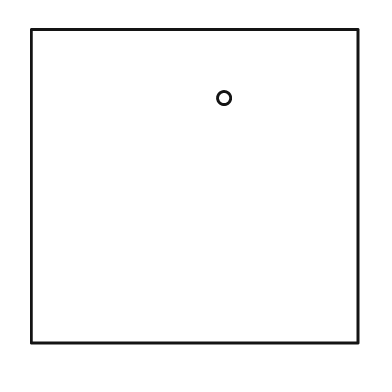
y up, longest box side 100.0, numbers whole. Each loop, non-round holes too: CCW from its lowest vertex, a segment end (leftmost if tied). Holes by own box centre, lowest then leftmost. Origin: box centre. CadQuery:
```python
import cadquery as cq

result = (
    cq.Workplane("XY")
    .moveTo(-50.0, -48.0)
    .lineTo(50.0, -48.0)
    .lineTo(50.0, 48.0)
    .lineTo(-50.0, 48.0)
    .close()
    .moveTo(9.0, 27.0)
    .circle(2.0)
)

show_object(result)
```